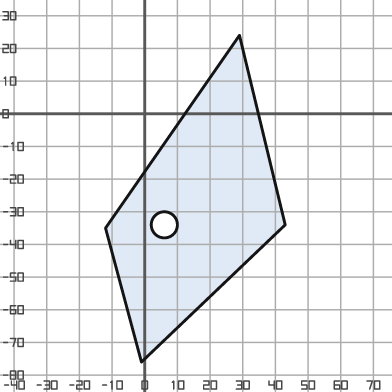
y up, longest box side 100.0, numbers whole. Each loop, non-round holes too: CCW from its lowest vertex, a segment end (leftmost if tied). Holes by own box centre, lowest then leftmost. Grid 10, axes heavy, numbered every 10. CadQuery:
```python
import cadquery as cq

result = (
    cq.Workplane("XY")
    .moveTo(-1.0, -76.0)
    .lineTo(43.0, -34.0)
    .lineTo(29.0, 24.0)
    .lineTo(-12.0, -35.0)
    .close()
    .moveTo(6.0, -34.0)
    .circle(4.0)
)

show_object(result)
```